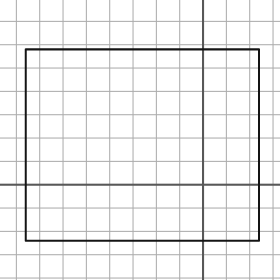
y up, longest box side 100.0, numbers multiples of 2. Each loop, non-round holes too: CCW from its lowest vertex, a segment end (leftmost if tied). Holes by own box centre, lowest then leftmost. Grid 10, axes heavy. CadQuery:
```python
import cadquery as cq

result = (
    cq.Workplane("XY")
    .moveTo(-76.0, -24.0)
    .lineTo(24.0, -24.0)
    .lineTo(24.0, 58.0)
    .lineTo(-76.0, 58.0)
    .close()
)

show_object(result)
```